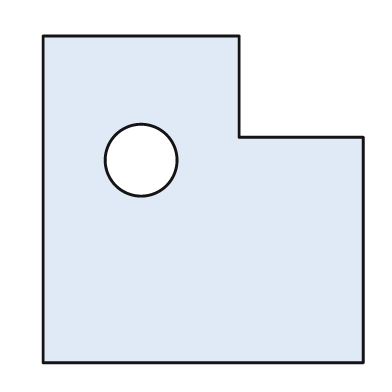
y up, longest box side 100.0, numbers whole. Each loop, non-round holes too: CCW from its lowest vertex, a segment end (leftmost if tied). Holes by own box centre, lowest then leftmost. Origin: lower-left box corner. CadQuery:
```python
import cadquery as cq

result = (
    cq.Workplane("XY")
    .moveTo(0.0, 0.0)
    .lineTo(98.0, 0.0)
    .lineTo(98.0, 69.0)
    .lineTo(60.0, 69.0)
    .lineTo(60.0, 100.0)
    .lineTo(0.0, 100.0)
    .close()
    .moveTo(30.0, 62.0)
    .circle(11.0)
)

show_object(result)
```